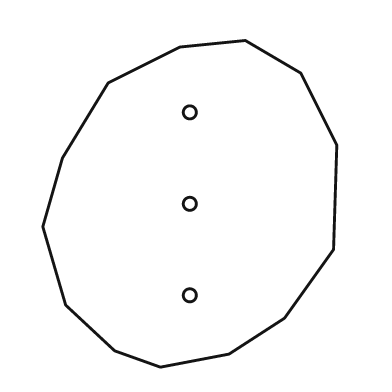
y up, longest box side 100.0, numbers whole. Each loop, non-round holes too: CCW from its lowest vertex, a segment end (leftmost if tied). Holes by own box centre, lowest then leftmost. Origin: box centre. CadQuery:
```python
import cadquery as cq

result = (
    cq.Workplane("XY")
    .moveTo(-9.0, -50.0)
    .lineTo(12.0, -46.0)
    .lineTo(29.0, -35.0)
    .lineTo(44.0, -14.0)
    .lineTo(45.0, 18.0)
    .lineTo(34.0, 40.0)
    .lineTo(17.0, 50.0)
    .lineTo(-3.0, 48.0)
    .lineTo(-25.0, 37.0)
    .lineTo(-39.0, 14.0)
    .lineTo(-45.0, -7.0)
    .lineTo(-38.0, -31.0)
    .lineTo(-23.0, -45.0)
    .close()
    .moveTo(0.0, -28.0)
    .circle(2.0)
    .moveTo(0.0, 0.0)
    .circle(2.0)
    .moveTo(0.0, 28.0)
    .circle(2.0)
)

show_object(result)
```